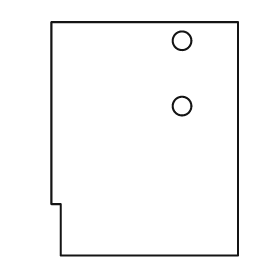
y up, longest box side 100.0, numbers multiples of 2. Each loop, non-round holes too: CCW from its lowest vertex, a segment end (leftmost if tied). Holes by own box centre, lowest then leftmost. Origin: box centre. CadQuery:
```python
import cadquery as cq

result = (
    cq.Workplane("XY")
    .moveTo(-36.0, -50.0)
    .lineTo(40.0, -50.0)
    .lineTo(40.0, 50.0)
    .lineTo(-40.0, 50.0)
    .lineTo(-40.0, -28.0)
    .lineTo(-36.0, -28.0)
    .close()
    .moveTo(16.0, 14.0)
    .circle(4.0)
    .moveTo(16.0, 42.0)
    .circle(4.0)
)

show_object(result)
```